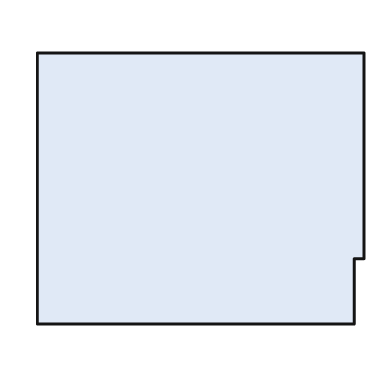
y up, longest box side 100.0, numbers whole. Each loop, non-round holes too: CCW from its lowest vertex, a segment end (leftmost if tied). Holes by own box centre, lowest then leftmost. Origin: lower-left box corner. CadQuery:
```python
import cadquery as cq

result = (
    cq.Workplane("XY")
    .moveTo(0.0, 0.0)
    .lineTo(97.0, 0.0)
    .lineTo(97.0, 20.0)
    .lineTo(100.0, 20.0)
    .lineTo(100.0, 83.0)
    .lineTo(0.0, 83.0)
    .close()
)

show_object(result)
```